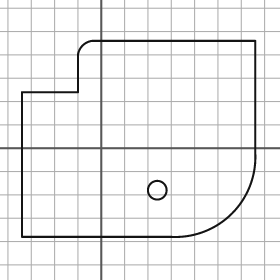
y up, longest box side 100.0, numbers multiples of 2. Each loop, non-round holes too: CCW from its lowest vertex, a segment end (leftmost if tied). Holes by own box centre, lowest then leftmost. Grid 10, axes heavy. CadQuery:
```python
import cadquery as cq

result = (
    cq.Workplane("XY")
    .moveTo(-34.0, -38.0)
    .lineTo(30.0, -38.0)
    .threePointArc((56.0, -28.0), (66.0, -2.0))
    .lineTo(66.0, 46.0)
    .lineTo(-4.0, 46.0)
    .threePointArc((-8.0, 44.0), (-10.0, 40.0))
    .lineTo(-10.0, 24.0)
    .lineTo(-34.0, 24.0)
    .close()
    .moveTo(24.0, -18.0)
    .circle(4.0)
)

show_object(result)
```